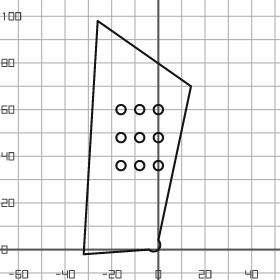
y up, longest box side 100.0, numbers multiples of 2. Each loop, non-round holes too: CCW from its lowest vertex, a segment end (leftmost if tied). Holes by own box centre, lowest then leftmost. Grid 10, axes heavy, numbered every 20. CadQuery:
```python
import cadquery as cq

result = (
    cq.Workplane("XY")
    .moveTo(-32.0, -2.0)
    .lineTo(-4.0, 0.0)
    .threePointArc((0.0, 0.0), (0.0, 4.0))
    .lineTo(14.0, 70.0)
    .lineTo(-26.0, 98.0)
    .close()
    .moveTo(-16.0, 36.0)
    .circle(2.0)
    .moveTo(-8.0, 36.0)
    .circle(2.0)
    .moveTo(0.0, 36.0)
    .circle(2.0)
    .moveTo(-16.0, 48.0)
    .circle(2.0)
    .moveTo(-8.0, 48.0)
    .circle(2.0)
    .moveTo(0.0, 48.0)
    .circle(2.0)
    .moveTo(-16.0, 60.0)
    .circle(2.0)
    .moveTo(-8.0, 60.0)
    .circle(2.0)
    .moveTo(0.0, 60.0)
    .circle(2.0)
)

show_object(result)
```